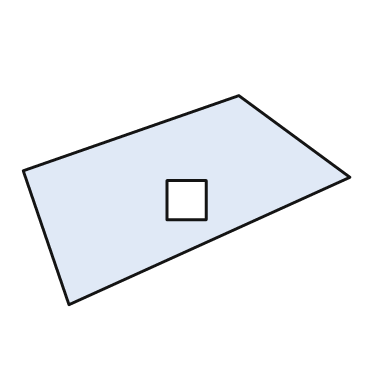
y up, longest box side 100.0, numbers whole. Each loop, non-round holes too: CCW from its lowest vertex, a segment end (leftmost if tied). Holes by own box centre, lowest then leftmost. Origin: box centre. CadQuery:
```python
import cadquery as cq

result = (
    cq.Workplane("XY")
    .moveTo(-36.0, -32.0)
    .lineTo(50.0, 7.0)
    .lineTo(16.0, 32.0)
    .lineTo(-50.0, 9.0)
    .close()
    .moveTo(-6.0, -6.0)
    .lineTo(6.0, -6.0)
    .lineTo(6.0, 6.0)
    .lineTo(-6.0, 6.0)
    .close()
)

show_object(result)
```